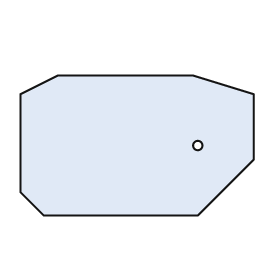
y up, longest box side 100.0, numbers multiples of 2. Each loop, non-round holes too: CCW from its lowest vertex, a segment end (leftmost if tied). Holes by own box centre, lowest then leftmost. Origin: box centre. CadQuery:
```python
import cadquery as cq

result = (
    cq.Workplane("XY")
    .moveTo(-40.0, -30.0)
    .lineTo(26.0, -30.0)
    .lineTo(50.0, -6.0)
    .lineTo(50.0, 22.0)
    .lineTo(24.0, 30.0)
    .lineTo(-34.0, 30.0)
    .lineTo(-50.0, 22.0)
    .lineTo(-50.0, -20.0)
    .close()
    .moveTo(26.0, 0.0)
    .circle(2.0)
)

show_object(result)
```